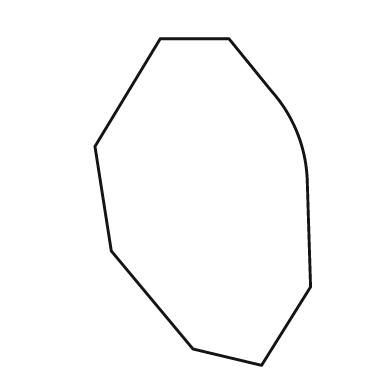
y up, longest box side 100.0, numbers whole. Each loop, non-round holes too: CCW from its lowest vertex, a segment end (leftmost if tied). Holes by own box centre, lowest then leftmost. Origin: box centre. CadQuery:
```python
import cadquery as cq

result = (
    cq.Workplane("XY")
    .moveTo(18.0, -50.0)
    .lineTo(33.0, -26.0)
    .lineTo(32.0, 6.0)
    .threePointArc((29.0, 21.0), (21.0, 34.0))
    .lineTo(8.0, 50.0)
    .lineTo(-13.0, 50.0)
    .lineTo(-33.0, 17.0)
    .lineTo(-28.0, -15.0)
    .lineTo(-3.0, -45.0)
    .close()
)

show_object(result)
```